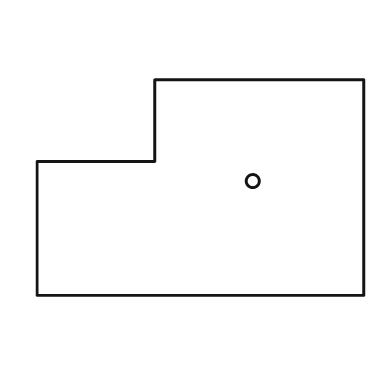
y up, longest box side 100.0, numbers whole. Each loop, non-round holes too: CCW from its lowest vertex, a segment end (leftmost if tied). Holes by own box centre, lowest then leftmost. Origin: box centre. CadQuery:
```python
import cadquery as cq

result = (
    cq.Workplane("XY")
    .moveTo(-50.0, -33.0)
    .lineTo(50.0, -33.0)
    .lineTo(50.0, 33.0)
    .lineTo(-14.0, 33.0)
    .lineTo(-14.0, 8.0)
    .lineTo(-50.0, 8.0)
    .close()
    .moveTo(16.0, 2.0)
    .circle(2.0)
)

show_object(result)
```